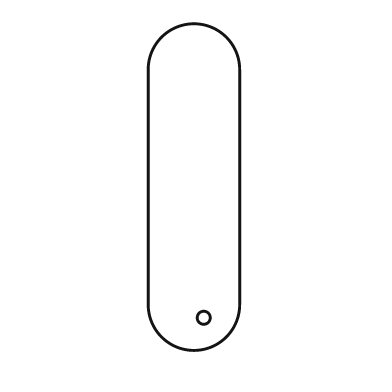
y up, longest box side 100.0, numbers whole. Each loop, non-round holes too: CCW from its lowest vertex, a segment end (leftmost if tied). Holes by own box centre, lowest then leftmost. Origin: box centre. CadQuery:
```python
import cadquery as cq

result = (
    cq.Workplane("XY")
    .moveTo(-14.0, -36.0)
    .threePointArc((0.0, -50.0), (14.0, -36.0))
    .lineTo(14.0, 36.0)
    .threePointArc((0.0, 50.0), (-14.0, 36.0))
    .close()
    .moveTo(3.0, -40.0)
    .circle(2.0)
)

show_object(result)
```